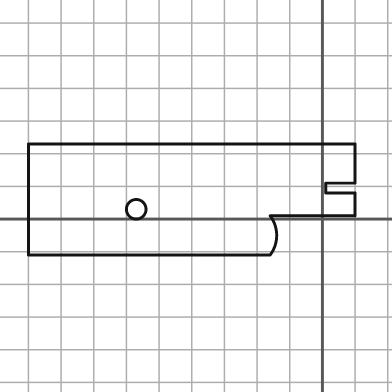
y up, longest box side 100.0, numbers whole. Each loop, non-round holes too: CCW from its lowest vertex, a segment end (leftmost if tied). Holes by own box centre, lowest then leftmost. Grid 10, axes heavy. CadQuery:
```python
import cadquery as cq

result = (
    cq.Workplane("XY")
    .moveTo(-90.0, -11.0)
    .lineTo(-16.0, -11.0)
    .threePointArc((-14.0, -5.0), (-16.0, 1.0))
    .lineTo(10.0, 1.0)
    .lineTo(10.0, 8.0)
    .lineTo(1.0, 8.0)
    .lineTo(1.0, 11.0)
    .lineTo(10.0, 11.0)
    .lineTo(10.0, 23.0)
    .lineTo(-90.0, 23.0)
    .close()
    .moveTo(-57.0, 3.0)
    .circle(3.0)
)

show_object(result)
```